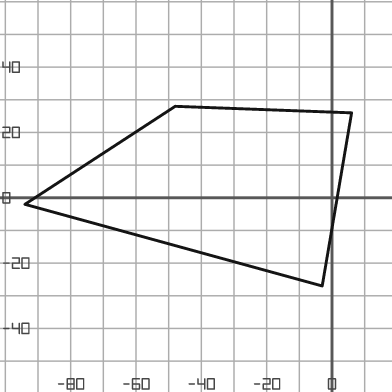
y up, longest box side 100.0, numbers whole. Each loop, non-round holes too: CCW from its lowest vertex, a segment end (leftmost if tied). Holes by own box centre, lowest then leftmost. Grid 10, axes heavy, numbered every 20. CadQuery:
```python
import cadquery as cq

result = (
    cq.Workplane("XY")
    .moveTo(-3.0, -27.0)
    .lineTo(6.0, 26.0)
    .lineTo(-48.0, 28.0)
    .lineTo(-94.0, -2.0)
    .close()
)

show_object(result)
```